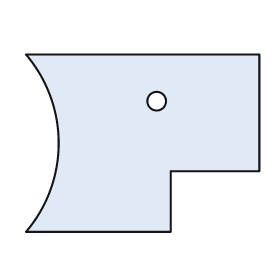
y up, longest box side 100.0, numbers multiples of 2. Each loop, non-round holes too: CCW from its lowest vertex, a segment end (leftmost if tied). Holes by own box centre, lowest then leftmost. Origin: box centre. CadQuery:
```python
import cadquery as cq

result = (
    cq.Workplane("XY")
    .moveTo(-50.0, -38.0)
    .lineTo(12.0, -38.0)
    .lineTo(12.0, -12.0)
    .lineTo(50.0, -12.0)
    .lineTo(50.0, 38.0)
    .lineTo(-50.0, 38.0)
    .threePointArc((-36.0, 0.0), (-50.0, -38.0))
    .close()
    .moveTo(6.0, 18.0)
    .circle(4.0)
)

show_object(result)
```